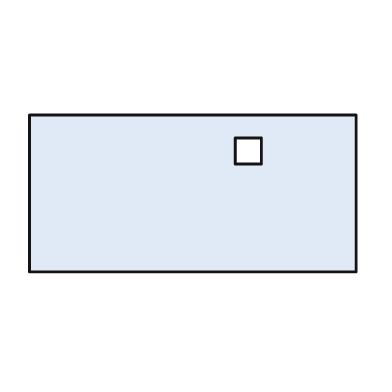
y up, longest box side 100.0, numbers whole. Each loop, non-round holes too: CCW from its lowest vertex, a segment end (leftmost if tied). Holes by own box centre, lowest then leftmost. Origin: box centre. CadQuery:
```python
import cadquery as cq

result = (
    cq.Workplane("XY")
    .moveTo(-50.0, -24.0)
    .lineTo(50.0, -24.0)
    .lineTo(50.0, 24.0)
    .lineTo(-50.0, 24.0)
    .close()
    .moveTo(13.0, 9.0)
    .lineTo(21.0, 9.0)
    .lineTo(21.0, 17.0)
    .lineTo(13.0, 17.0)
    .close()
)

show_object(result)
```